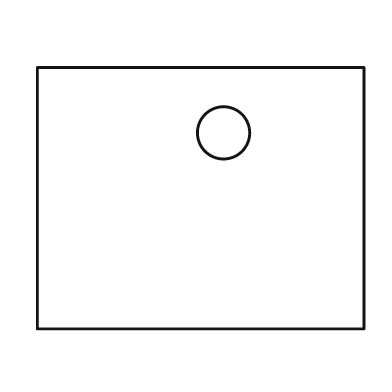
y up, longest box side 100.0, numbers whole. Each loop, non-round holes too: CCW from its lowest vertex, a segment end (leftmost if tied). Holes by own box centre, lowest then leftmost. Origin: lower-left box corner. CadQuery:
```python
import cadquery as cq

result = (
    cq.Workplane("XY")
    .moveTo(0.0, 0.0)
    .lineTo(100.0, 0.0)
    .lineTo(100.0, 80.0)
    .lineTo(0.0, 80.0)
    .close()
    .moveTo(57.0, 60.0)
    .circle(8.0)
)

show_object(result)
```